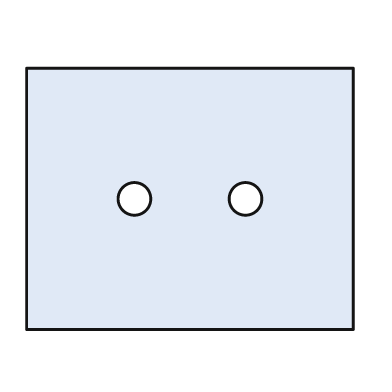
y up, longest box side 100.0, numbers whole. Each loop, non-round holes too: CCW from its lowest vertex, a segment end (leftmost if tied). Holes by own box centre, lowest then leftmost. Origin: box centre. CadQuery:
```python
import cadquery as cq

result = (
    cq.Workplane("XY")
    .moveTo(-50.0, -40.0)
    .lineTo(50.0, -40.0)
    .lineTo(50.0, 40.0)
    .lineTo(-50.0, 40.0)
    .close()
    .moveTo(-17.0, 0.0)
    .circle(5.0)
    .moveTo(17.0, 0.0)
    .circle(5.0)
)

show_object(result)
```